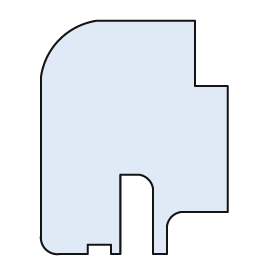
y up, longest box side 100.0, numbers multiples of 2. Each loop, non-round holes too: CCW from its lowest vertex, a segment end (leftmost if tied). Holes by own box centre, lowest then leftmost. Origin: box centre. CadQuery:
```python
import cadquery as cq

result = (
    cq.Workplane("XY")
    .moveTo(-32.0, -50.0)
    .lineTo(-20.0, -50.0)
    .lineTo(-20.0, -46.0)
    .lineTo(-10.0, -46.0)
    .lineTo(-10.0, -50.0)
    .lineTo(-6.0, -50.0)
    .lineTo(-6.0, -16.0)
    .lineTo(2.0, -16.0)
    .threePointArc((6.0, -18.0), (8.0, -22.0))
    .lineTo(8.0, -50.0)
    .lineTo(14.0, -50.0)
    .lineTo(14.0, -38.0)
    .threePointArc((16.0, -34.0), (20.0, -32.0))
    .lineTo(40.0, -32.0)
    .lineTo(40.0, 22.0)
    .lineTo(26.0, 22.0)
    .lineTo(26.0, 50.0)
    .lineTo(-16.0, 50.0)
    .threePointArc((-32.0, 42.0), (-40.0, 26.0))
    .lineTo(-40.0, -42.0)
    .threePointArc((-38.0, -48.0), (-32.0, -50.0))
    .close()
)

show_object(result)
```